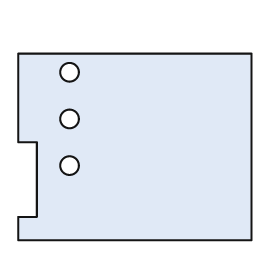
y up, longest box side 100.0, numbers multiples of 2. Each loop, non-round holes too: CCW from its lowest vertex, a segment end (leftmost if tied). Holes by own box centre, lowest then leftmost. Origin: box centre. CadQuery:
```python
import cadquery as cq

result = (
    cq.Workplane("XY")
    .moveTo(-50.0, -40.0)
    .lineTo(50.0, -40.0)
    .lineTo(50.0, 40.0)
    .lineTo(-50.0, 40.0)
    .lineTo(-50.0, 2.0)
    .lineTo(-42.0, 2.0)
    .lineTo(-42.0, -30.0)
    .lineTo(-50.0, -30.0)
    .close()
    .moveTo(-28.0, -8.0)
    .circle(4.0)
    .moveTo(-28.0, 12.0)
    .circle(4.0)
    .moveTo(-28.0, 32.0)
    .circle(4.0)
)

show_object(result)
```